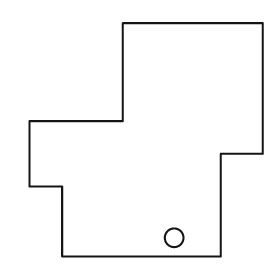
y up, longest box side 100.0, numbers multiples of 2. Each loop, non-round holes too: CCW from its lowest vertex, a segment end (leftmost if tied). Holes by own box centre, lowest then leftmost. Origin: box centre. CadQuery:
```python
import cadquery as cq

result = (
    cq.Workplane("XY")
    .moveTo(-36.0, -50.0)
    .lineTo(32.0, -50.0)
    .lineTo(32.0, -6.0)
    .lineTo(50.0, -6.0)
    .lineTo(50.0, 50.0)
    .lineTo(-10.0, 50.0)
    .lineTo(-10.0, 8.0)
    .lineTo(-50.0, 8.0)
    .lineTo(-50.0, -20.0)
    .lineTo(-36.0, -20.0)
    .close()
    .moveTo(12.0, -42.0)
    .circle(4.0)
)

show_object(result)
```